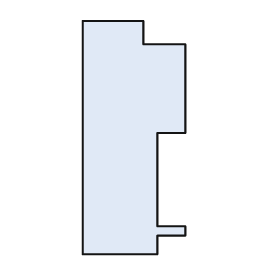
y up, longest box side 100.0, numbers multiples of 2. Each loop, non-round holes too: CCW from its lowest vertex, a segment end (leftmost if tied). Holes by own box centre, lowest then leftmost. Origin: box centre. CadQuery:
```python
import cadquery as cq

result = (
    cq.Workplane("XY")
    .moveTo(-22.0, -50.0)
    .lineTo(10.0, -50.0)
    .lineTo(10.0, -42.0)
    .lineTo(22.0, -42.0)
    .lineTo(22.0, -38.0)
    .lineTo(10.0, -38.0)
    .lineTo(10.0, 2.0)
    .lineTo(22.0, 2.0)
    .lineTo(22.0, 40.0)
    .lineTo(4.0, 40.0)
    .lineTo(4.0, 50.0)
    .lineTo(-22.0, 50.0)
    .close()
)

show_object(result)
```